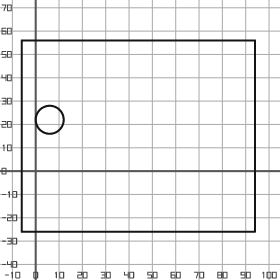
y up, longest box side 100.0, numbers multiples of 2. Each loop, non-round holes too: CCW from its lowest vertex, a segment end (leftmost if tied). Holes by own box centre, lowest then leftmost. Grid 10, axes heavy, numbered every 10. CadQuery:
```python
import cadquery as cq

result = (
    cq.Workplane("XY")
    .moveTo(-6.0, -26.0)
    .lineTo(94.0, -26.0)
    .lineTo(94.0, 56.0)
    .lineTo(-6.0, 56.0)
    .close()
    .moveTo(6.0, 22.0)
    .circle(6.0)
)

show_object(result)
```